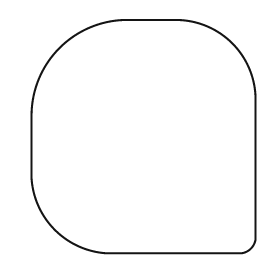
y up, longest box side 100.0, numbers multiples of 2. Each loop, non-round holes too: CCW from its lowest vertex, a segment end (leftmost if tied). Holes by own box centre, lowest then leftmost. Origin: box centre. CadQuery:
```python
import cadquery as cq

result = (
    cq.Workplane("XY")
    .moveTo(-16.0, -50.0)
    .lineTo(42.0, -50.0)
    .threePointArc((46.0, -48.0), (48.0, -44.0))
    .lineTo(48.0, 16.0)
    .threePointArc((38.0, 40.0), (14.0, 50.0))
    .lineTo(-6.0, 50.0)
    .threePointArc((-36.0, 38.0), (-48.0, 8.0))
    .lineTo(-48.0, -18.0)
    .threePointArc((-38.0, -40.0), (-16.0, -50.0))
    .close()
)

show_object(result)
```